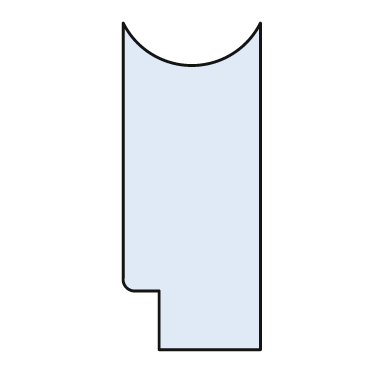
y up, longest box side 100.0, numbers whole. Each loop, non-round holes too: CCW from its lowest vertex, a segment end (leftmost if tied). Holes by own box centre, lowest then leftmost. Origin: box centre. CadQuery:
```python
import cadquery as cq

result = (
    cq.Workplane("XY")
    .moveTo(-10.0, -50.0)
    .lineTo(21.0, -50.0)
    .lineTo(21.0, 50.0)
    .threePointArc((0.0, 37.0), (-21.0, 50.0))
    .lineTo(-21.0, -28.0)
    .threePointArc((-20.0, -31.0), (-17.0, -32.0))
    .lineTo(-10.0, -32.0)
    .close()
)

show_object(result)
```